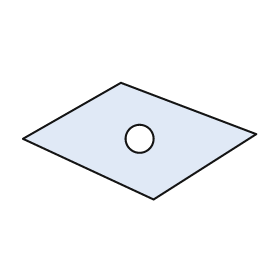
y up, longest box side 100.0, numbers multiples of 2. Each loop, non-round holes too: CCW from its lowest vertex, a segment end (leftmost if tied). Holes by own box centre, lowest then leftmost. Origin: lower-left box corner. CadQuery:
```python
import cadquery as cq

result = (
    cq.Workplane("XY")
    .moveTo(56.0, 0.0)
    .lineTo(100.0, 28.0)
    .lineTo(42.0, 50.0)
    .lineTo(0.0, 26.0)
    .close()
    .moveTo(50.0, 26.0)
    .circle(6.0)
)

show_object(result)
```